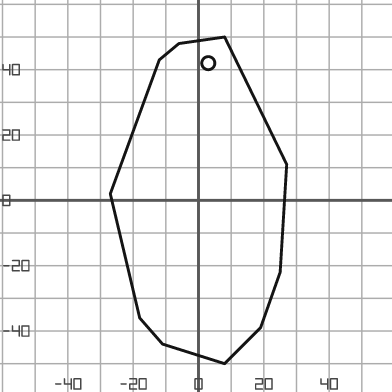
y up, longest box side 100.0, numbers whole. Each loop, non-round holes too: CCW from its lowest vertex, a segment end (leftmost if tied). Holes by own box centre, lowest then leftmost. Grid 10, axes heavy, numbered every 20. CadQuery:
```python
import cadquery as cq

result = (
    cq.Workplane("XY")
    .moveTo(8.0, -50.0)
    .lineTo(19.0, -39.0)
    .lineTo(25.0, -22.0)
    .lineTo(27.0, 11.0)
    .lineTo(8.0, 50.0)
    .lineTo(-6.0, 48.0)
    .lineTo(-12.0, 43.0)
    .lineTo(-27.0, 2.0)
    .lineTo(-18.0, -36.0)
    .lineTo(-11.0, -44.0)
    .close()
    .moveTo(3.0, 42.0)
    .circle(2.0)
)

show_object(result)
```